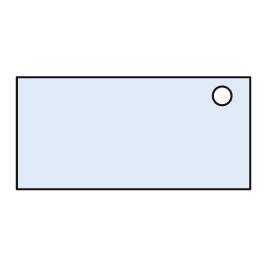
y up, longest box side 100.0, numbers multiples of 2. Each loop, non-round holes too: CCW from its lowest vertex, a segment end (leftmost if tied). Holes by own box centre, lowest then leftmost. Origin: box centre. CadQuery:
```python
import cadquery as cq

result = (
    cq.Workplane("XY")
    .moveTo(-50.0, -24.0)
    .lineTo(50.0, -24.0)
    .lineTo(50.0, 24.0)
    .lineTo(-50.0, 24.0)
    .close()
    .moveTo(38.0, 16.0)
    .circle(4.0)
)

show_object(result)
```